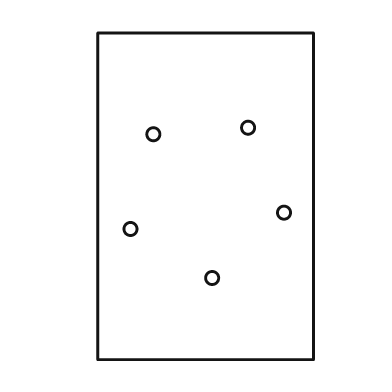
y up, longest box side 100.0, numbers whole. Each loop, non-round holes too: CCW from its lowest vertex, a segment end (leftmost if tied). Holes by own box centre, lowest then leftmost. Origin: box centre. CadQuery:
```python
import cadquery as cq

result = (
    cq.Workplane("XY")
    .moveTo(-33.0, -50.0)
    .lineTo(33.0, -50.0)
    .lineTo(33.0, 50.0)
    .lineTo(-33.0, 50.0)
    .close()
    .moveTo(2.0, -25.0)
    .circle(2.0)
    .moveTo(-23.0, -10.0)
    .circle(2.0)
    .moveTo(24.0, -5.0)
    .circle(2.0)
    .moveTo(-16.0, 19.0)
    .circle(2.0)
    .moveTo(13.0, 21.0)
    .circle(2.0)
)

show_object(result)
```